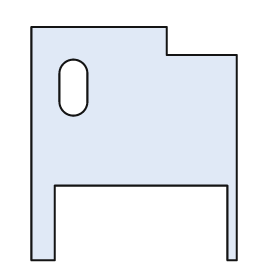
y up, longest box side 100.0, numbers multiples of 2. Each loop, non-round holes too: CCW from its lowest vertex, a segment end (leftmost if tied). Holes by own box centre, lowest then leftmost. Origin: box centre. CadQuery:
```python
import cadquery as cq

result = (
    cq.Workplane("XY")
    .moveTo(-44.0, -50.0)
    .lineTo(-34.0, -50.0)
    .lineTo(-34.0, -18.0)
    .lineTo(40.0, -18.0)
    .lineTo(40.0, -50.0)
    .lineTo(44.0, -50.0)
    .lineTo(44.0, 38.0)
    .lineTo(14.0, 38.0)
    .lineTo(14.0, 50.0)
    .lineTo(-44.0, 50.0)
    .close()
    .moveTo(-32.0, 18.0)
    .threePointArc((-26.0, 12.0), (-20.0, 18.0))
    .lineTo(-20.0, 30.0)
    .threePointArc((-26.0, 36.0), (-32.0, 30.0))
    .close()
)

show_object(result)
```